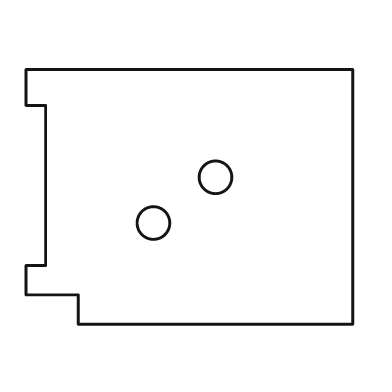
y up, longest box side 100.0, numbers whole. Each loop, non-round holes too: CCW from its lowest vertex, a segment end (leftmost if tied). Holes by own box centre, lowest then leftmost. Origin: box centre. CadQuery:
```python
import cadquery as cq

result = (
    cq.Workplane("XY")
    .moveTo(-34.0, -39.0)
    .lineTo(50.0, -39.0)
    .lineTo(50.0, 39.0)
    .lineTo(-50.0, 39.0)
    .lineTo(-50.0, 28.0)
    .lineTo(-44.0, 28.0)
    .lineTo(-44.0, -21.0)
    .lineTo(-50.0, -21.0)
    .lineTo(-50.0, -30.0)
    .lineTo(-34.0, -30.0)
    .close()
    .moveTo(-11.0, -8.0)
    .circle(5.0)
    .moveTo(8.0, 6.0)
    .circle(5.0)
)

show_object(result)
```